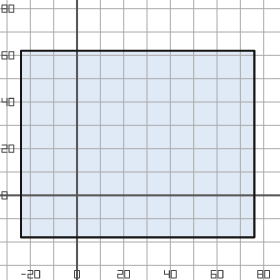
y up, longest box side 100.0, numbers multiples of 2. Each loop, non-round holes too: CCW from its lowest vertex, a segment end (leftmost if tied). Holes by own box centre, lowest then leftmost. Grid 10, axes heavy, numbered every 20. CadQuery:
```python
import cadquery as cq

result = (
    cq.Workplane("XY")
    .moveTo(-24.0, -18.0)
    .lineTo(76.0, -18.0)
    .lineTo(76.0, 62.0)
    .lineTo(-24.0, 62.0)
    .close()
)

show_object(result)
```